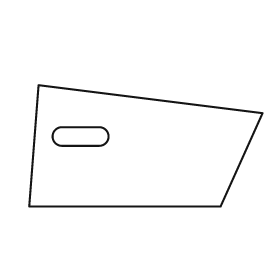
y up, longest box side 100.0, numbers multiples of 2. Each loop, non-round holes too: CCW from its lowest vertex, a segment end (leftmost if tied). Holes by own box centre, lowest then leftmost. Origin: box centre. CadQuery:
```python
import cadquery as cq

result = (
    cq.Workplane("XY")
    .moveTo(-50.0, -26.0)
    .lineTo(32.0, -26.0)
    .lineTo(50.0, 14.0)
    .lineTo(-46.0, 26.0)
    .close()
    .moveTo(-36.0, 0.0)
    .lineTo(-20.0, 0.0)
    .threePointArc((-16.0, 4.0), (-20.0, 8.0))
    .lineTo(-36.0, 8.0)
    .threePointArc((-40.0, 4.0), (-36.0, 0.0))
    .close()
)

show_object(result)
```